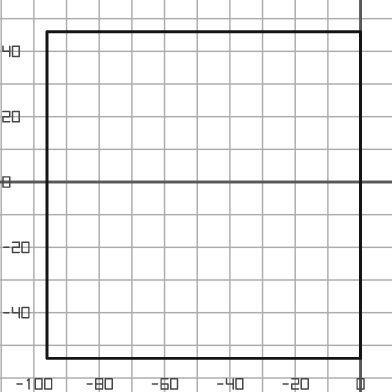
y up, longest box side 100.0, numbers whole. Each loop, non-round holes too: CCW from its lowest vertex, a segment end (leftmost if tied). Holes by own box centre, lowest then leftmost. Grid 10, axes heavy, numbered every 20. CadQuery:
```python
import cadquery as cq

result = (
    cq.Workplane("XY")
    .moveTo(-96.0, -54.0)
    .lineTo(0.0, -54.0)
    .lineTo(0.0, 46.0)
    .lineTo(-96.0, 46.0)
    .close()
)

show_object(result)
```